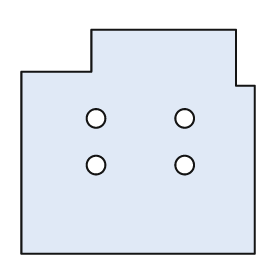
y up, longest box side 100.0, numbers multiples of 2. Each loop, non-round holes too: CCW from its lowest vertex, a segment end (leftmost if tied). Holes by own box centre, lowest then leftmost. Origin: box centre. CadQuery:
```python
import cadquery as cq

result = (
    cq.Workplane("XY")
    .moveTo(-50.0, -48.0)
    .lineTo(50.0, -48.0)
    .lineTo(50.0, 24.0)
    .lineTo(42.0, 24.0)
    .lineTo(42.0, 48.0)
    .lineTo(-20.0, 48.0)
    .lineTo(-20.0, 30.0)
    .lineTo(-50.0, 30.0)
    .close()
    .moveTo(-18.0, -10.0)
    .circle(4.0)
    .moveTo(20.0, -10.0)
    .circle(4.0)
    .moveTo(-18.0, 10.0)
    .circle(4.0)
    .moveTo(20.0, 10.0)
    .circle(4.0)
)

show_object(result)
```